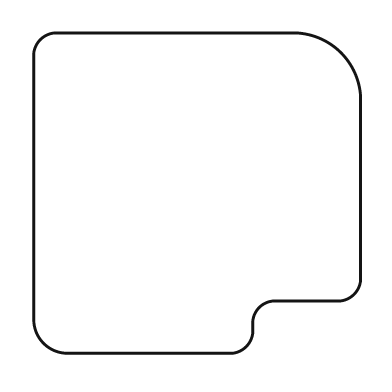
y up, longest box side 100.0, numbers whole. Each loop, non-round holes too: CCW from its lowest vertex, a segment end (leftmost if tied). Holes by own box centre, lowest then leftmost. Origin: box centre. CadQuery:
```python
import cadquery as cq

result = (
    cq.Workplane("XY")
    .moveTo(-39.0, -49.0)
    .lineTo(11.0, -49.0)
    .threePointArc((15.0, -47.0), (17.0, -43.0))
    .lineTo(17.0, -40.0)
    .threePointArc((19.0, -35.0), (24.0, -33.0))
    .lineTo(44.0, -33.0)
    .threePointArc((48.0, -31.0), (50.0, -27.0))
    .lineTo(50.0, 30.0)
    .threePointArc((44.0, 43.0), (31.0, 49.0))
    .lineTo(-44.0, 49.0)
    .threePointArc((-48.0, 47.0), (-50.0, 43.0))
    .lineTo(-50.0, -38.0)
    .threePointArc((-47.0, -46.0), (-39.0, -49.0))
    .close()
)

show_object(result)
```